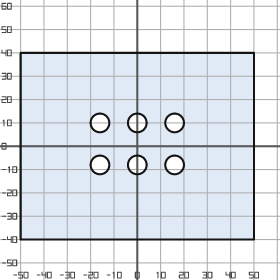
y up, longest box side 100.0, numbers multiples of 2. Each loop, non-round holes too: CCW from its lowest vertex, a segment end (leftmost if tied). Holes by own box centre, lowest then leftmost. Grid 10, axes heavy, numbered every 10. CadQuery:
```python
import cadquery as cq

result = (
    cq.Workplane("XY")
    .moveTo(-50.0, -40.0)
    .lineTo(50.0, -40.0)
    .lineTo(50.0, 40.0)
    .lineTo(-50.0, 40.0)
    .close()
    .moveTo(-16.0, -8.0)
    .circle(4.0)
    .moveTo(0.0, -8.0)
    .circle(4.0)
    .moveTo(16.0, -8.0)
    .circle(4.0)
    .moveTo(-16.0, 10.0)
    .circle(4.0)
    .moveTo(0.0, 10.0)
    .circle(4.0)
    .moveTo(16.0, 10.0)
    .circle(4.0)
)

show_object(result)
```